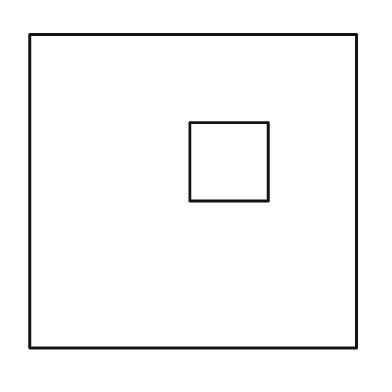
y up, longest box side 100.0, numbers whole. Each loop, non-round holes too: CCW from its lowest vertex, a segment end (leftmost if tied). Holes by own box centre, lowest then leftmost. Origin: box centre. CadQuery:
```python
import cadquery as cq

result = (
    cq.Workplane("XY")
    .moveTo(-50.0, -48.0)
    .lineTo(50.0, -48.0)
    .lineTo(50.0, 48.0)
    .lineTo(-50.0, 48.0)
    .close()
    .moveTo(-1.0, -3.0)
    .lineTo(23.0, -3.0)
    .lineTo(23.0, 21.0)
    .lineTo(-1.0, 21.0)
    .close()
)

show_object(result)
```